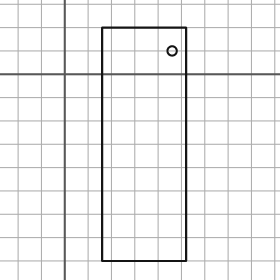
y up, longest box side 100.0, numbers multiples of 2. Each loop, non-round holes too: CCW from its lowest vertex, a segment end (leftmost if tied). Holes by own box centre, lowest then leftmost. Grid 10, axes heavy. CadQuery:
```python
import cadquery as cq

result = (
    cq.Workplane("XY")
    .moveTo(16.0, -80.0)
    .lineTo(52.0, -80.0)
    .lineTo(52.0, 20.0)
    .lineTo(16.0, 20.0)
    .close()
    .moveTo(46.0, 10.0)
    .circle(2.0)
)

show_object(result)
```